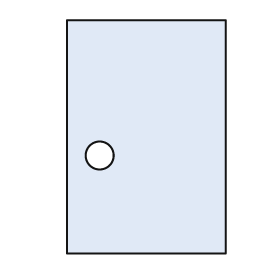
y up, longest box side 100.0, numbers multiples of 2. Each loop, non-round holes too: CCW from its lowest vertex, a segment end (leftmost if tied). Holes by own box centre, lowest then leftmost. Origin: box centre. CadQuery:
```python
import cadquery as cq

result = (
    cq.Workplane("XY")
    .moveTo(-34.0, -50.0)
    .lineTo(34.0, -50.0)
    .lineTo(34.0, 50.0)
    .lineTo(-34.0, 50.0)
    .close()
    .moveTo(-20.0, -8.0)
    .circle(6.0)
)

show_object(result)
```